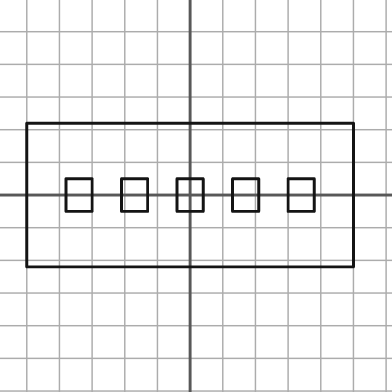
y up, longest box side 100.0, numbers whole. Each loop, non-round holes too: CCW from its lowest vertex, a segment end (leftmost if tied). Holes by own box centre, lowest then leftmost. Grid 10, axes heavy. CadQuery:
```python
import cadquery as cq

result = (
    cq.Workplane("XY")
    .moveTo(-50.0, -22.0)
    .lineTo(50.0, -22.0)
    .lineTo(50.0, 22.0)
    .lineTo(-50.0, 22.0)
    .close()
    .moveTo(-38.0, -5.0)
    .lineTo(-30.0, -5.0)
    .lineTo(-30.0, 5.0)
    .lineTo(-38.0, 5.0)
    .close()
    .moveTo(-21.0, -5.0)
    .lineTo(-13.0, -5.0)
    .lineTo(-13.0, 5.0)
    .lineTo(-21.0, 5.0)
    .close()
    .moveTo(-4.0, -5.0)
    .lineTo(4.0, -5.0)
    .lineTo(4.0, 5.0)
    .lineTo(-4.0, 5.0)
    .close()
    .moveTo(13.0, -5.0)
    .lineTo(21.0, -5.0)
    .lineTo(21.0, 5.0)
    .lineTo(13.0, 5.0)
    .close()
    .moveTo(30.0, -5.0)
    .lineTo(38.0, -5.0)
    .lineTo(38.0, 5.0)
    .lineTo(30.0, 5.0)
    .close()
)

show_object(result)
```